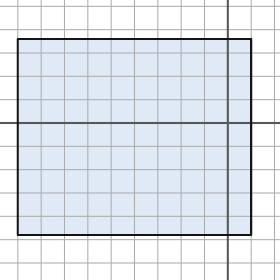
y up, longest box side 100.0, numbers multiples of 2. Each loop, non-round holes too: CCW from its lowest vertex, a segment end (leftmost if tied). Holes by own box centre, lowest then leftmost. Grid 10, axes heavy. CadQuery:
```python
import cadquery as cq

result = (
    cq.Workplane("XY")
    .moveTo(-90.0, -48.0)
    .lineTo(10.0, -48.0)
    .lineTo(10.0, 36.0)
    .lineTo(-90.0, 36.0)
    .close()
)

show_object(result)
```